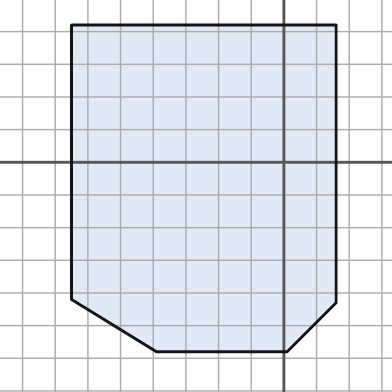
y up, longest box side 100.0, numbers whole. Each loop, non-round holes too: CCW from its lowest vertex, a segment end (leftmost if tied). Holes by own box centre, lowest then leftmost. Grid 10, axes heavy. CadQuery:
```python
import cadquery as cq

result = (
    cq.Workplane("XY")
    .moveTo(-39.0, -58.0)
    .lineTo(1.0, -58.0)
    .lineTo(16.0, -43.0)
    .lineTo(16.0, 42.0)
    .lineTo(-65.0, 42.0)
    .lineTo(-65.0, -42.0)
    .close()
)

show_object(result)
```